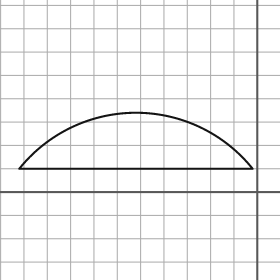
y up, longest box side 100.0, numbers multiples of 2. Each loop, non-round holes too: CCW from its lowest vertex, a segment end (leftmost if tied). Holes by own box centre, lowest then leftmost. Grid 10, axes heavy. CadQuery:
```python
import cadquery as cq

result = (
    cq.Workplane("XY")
    .moveTo(-102.0, 10.0)
    .lineTo(-2.0, 10.0)
    .threePointArc((-52.0, 34.0), (-102.0, 10.0))
    .close()
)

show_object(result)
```